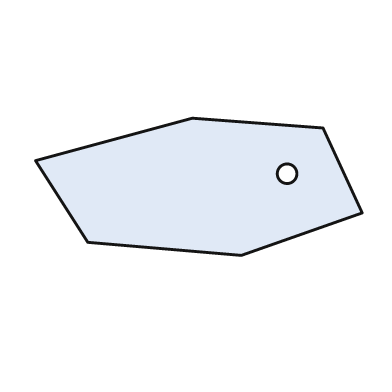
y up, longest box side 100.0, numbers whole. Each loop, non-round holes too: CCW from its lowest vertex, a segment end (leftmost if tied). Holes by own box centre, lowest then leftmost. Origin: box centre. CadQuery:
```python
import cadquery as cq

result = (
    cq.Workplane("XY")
    .moveTo(13.0, -21.0)
    .lineTo(50.0, -8.0)
    .lineTo(38.0, 18.0)
    .lineTo(-2.0, 21.0)
    .lineTo(-50.0, 8.0)
    .lineTo(-34.0, -17.0)
    .close()
    .moveTo(27.0, 4.0)
    .circle(3.0)
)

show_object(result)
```